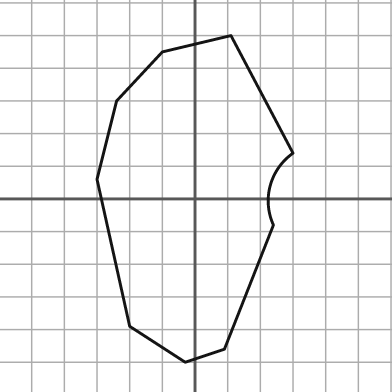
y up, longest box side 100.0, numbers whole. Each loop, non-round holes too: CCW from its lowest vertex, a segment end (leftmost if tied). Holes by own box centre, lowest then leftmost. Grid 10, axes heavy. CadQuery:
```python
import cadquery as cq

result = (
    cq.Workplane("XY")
    .moveTo(-3.0, -50.0)
    .lineTo(9.0, -46.0)
    .lineTo(24.0, -8.0)
    .threePointArc((23.0, 4.0), (30.0, 14.0))
    .lineTo(11.0, 50.0)
    .lineTo(-10.0, 45.0)
    .lineTo(-24.0, 30.0)
    .lineTo(-30.0, 6.0)
    .lineTo(-20.0, -39.0)
    .close()
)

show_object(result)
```